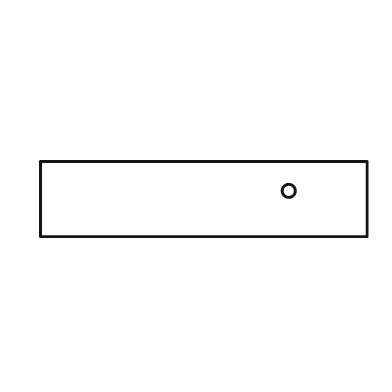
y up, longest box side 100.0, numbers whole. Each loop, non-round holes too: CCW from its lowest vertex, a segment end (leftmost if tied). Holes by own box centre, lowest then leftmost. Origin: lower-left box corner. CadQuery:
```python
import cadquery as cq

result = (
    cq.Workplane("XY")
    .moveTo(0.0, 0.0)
    .lineTo(100.0, 0.0)
    .lineTo(100.0, 23.0)
    .lineTo(0.0, 23.0)
    .close()
    .moveTo(76.0, 14.0)
    .circle(2.0)
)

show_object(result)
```